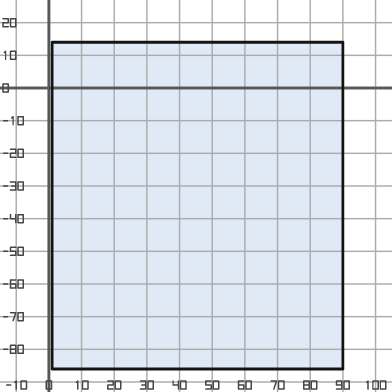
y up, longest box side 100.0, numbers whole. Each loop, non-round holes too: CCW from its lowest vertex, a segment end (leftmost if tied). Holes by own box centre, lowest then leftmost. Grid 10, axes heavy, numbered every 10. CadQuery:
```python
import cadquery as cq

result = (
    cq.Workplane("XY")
    .moveTo(1.0, -86.0)
    .lineTo(90.0, -86.0)
    .lineTo(90.0, 14.0)
    .lineTo(1.0, 14.0)
    .close()
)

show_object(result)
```